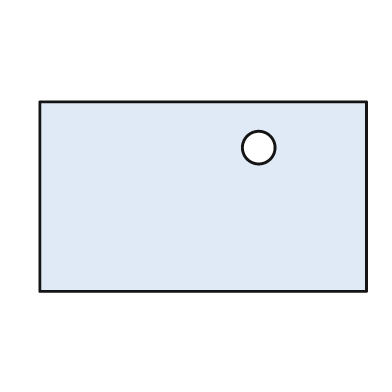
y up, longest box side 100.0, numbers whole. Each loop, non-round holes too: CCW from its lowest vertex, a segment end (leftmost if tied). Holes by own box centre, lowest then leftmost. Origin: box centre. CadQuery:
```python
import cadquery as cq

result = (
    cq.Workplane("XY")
    .moveTo(-50.0, -29.0)
    .lineTo(50.0, -29.0)
    .lineTo(50.0, 29.0)
    .lineTo(-50.0, 29.0)
    .close()
    .moveTo(17.0, 15.0)
    .circle(5.0)
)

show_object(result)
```